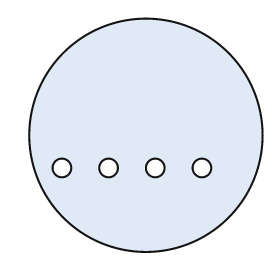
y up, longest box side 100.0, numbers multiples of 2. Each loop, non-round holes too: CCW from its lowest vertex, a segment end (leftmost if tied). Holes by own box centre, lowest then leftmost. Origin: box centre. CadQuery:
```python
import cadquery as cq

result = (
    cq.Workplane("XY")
    .moveTo(0.0, 0.0)
    .circle(50.0)
    .moveTo(-36.0, -14.0)
    .circle(4.0)
    .moveTo(-16.0, -14.0)
    .circle(4.0)
    .moveTo(4.0, -14.0)
    .circle(4.0)
    .moveTo(24.0, -14.0)
    .circle(4.0)
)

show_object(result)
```